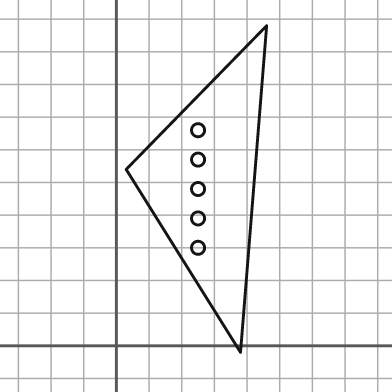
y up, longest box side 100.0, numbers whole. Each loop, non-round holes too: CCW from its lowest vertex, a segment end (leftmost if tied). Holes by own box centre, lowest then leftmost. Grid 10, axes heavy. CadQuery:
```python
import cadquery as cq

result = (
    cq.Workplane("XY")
    .moveTo(38.0, -2.0)
    .lineTo(46.0, 98.0)
    .lineTo(3.0, 54.0)
    .close()
    .moveTo(25.0, 30.0)
    .circle(2.0)
    .moveTo(25.0, 39.0)
    .circle(2.0)
    .moveTo(25.0, 48.0)
    .circle(2.0)
    .moveTo(25.0, 57.0)
    .circle(2.0)
    .moveTo(25.0, 66.0)
    .circle(2.0)
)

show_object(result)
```